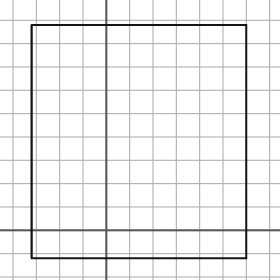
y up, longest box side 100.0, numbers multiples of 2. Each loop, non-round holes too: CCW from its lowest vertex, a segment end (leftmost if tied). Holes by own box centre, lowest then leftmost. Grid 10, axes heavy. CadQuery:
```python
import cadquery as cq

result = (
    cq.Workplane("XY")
    .moveTo(-32.0, -12.0)
    .lineTo(60.0, -12.0)
    .lineTo(60.0, 88.0)
    .lineTo(-32.0, 88.0)
    .close()
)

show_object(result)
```